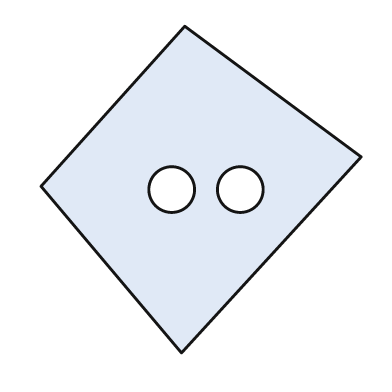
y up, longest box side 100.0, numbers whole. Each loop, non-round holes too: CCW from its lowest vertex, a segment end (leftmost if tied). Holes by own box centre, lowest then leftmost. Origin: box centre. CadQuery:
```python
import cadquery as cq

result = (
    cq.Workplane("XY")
    .moveTo(-6.0, -50.0)
    .lineTo(49.0, 10.0)
    .lineTo(-5.0, 50.0)
    .lineTo(-49.0, 1.0)
    .close()
    .moveTo(-9.0, 0.0)
    .circle(7.0)
    .moveTo(12.0, 0.0)
    .circle(7.0)
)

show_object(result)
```